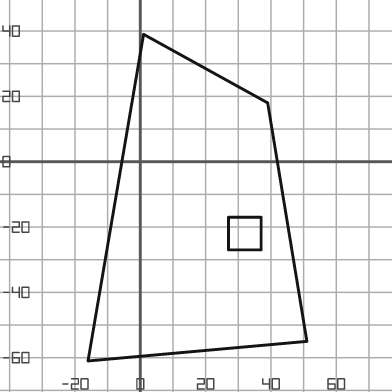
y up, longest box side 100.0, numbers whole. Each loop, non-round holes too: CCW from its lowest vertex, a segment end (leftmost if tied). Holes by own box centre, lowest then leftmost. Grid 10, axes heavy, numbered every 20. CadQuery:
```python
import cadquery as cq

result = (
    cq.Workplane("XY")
    .moveTo(-16.0, -61.0)
    .lineTo(51.0, -55.0)
    .lineTo(39.0, 18.0)
    .lineTo(1.0, 39.0)
    .close()
    .moveTo(27.0, -27.0)
    .lineTo(37.0, -27.0)
    .lineTo(37.0, -17.0)
    .lineTo(27.0, -17.0)
    .close()
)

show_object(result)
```